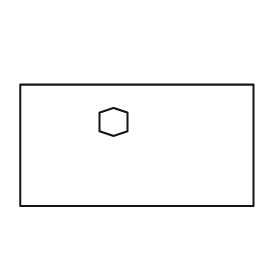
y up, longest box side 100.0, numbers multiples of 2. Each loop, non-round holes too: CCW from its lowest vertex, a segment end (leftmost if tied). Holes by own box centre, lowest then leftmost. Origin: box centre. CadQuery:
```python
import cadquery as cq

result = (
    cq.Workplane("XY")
    .moveTo(-50.0, -26.0)
    .lineTo(50.0, -26.0)
    .lineTo(50.0, 26.0)
    .lineTo(-50.0, 26.0)
    .close()
    .moveTo(-10.0, 4.0)
    .lineTo(-4.0, 6.0)
    .lineTo(-4.0, 14.0)
    .lineTo(-10.0, 16.0)
    .lineTo(-16.0, 14.0)
    .lineTo(-16.0, 6.0)
    .close()
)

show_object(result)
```